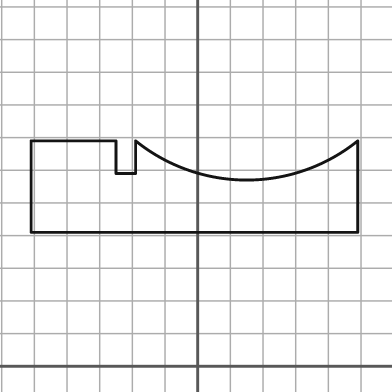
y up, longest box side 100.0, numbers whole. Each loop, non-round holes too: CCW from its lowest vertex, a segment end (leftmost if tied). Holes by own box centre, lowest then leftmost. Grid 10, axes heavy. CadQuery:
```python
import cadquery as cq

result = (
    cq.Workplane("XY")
    .moveTo(-51.0, 41.0)
    .lineTo(49.0, 41.0)
    .lineTo(49.0, 69.0)
    .threePointArc((15.0, 57.0), (-19.0, 69.0))
    .lineTo(-19.0, 59.0)
    .lineTo(-25.0, 59.0)
    .lineTo(-25.0, 69.0)
    .lineTo(-51.0, 69.0)
    .close()
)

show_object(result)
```